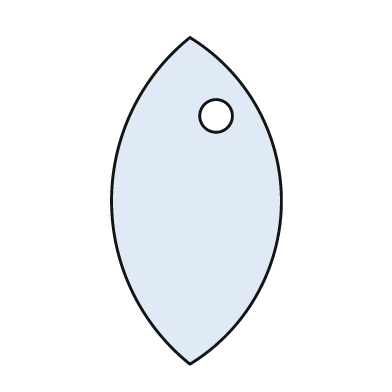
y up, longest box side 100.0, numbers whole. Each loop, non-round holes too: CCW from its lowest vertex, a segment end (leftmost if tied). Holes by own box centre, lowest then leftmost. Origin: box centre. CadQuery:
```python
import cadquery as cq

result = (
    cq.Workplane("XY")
    .moveTo(-2.0, -50.0)
    .threePointArc((26.0, 0.0), (-2.0, 50.0))
    .threePointArc((-26.0, 0.0), (-2.0, -50.0))
    .close()
    .moveTo(6.0, 26.0)
    .circle(5.0)
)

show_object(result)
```